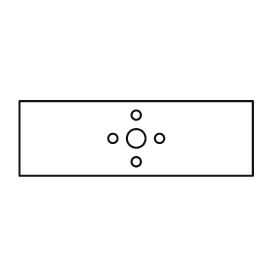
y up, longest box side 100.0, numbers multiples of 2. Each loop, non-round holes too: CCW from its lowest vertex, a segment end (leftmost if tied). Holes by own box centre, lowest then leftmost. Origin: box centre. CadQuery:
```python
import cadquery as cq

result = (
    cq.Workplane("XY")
    .moveTo(-50.0, -16.0)
    .lineTo(50.0, -16.0)
    .lineTo(50.0, 16.0)
    .lineTo(-50.0, 16.0)
    .close()
    .moveTo(0.0, -10.0)
    .circle(2.0)
    .moveTo(-10.0, 0.0)
    .circle(2.0)
    .moveTo(0.0, 0.0)
    .circle(4.0)
    .moveTo(10.0, 0.0)
    .circle(2.0)
    .moveTo(0.0, 10.0)
    .circle(2.0)
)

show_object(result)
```